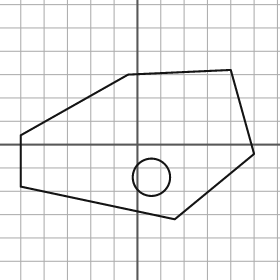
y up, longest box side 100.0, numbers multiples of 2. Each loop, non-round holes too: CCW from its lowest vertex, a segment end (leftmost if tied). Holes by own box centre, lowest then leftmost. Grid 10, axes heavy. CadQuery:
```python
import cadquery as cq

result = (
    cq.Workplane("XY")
    .moveTo(16.0, -32.0)
    .lineTo(50.0, -4.0)
    .lineTo(40.0, 32.0)
    .lineTo(-4.0, 30.0)
    .lineTo(-50.0, 4.0)
    .lineTo(-50.0, -18.0)
    .close()
    .moveTo(6.0, -14.0)
    .circle(8.0)
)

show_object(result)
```